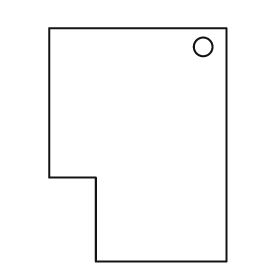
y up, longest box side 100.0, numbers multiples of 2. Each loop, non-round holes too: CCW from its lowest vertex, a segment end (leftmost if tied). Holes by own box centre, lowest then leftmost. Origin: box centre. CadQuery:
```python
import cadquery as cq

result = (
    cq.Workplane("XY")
    .moveTo(-18.0, -50.0)
    .lineTo(38.0, -50.0)
    .lineTo(38.0, 50.0)
    .lineTo(-38.0, 50.0)
    .lineTo(-38.0, -14.0)
    .lineTo(-18.0, -14.0)
    .close()
    .moveTo(28.0, 42.0)
    .circle(4.0)
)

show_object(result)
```